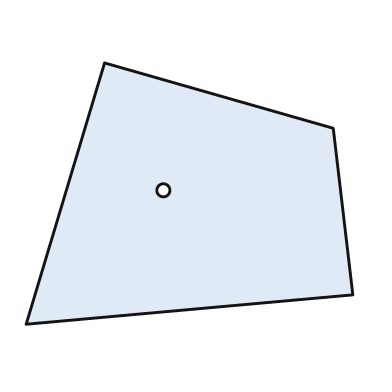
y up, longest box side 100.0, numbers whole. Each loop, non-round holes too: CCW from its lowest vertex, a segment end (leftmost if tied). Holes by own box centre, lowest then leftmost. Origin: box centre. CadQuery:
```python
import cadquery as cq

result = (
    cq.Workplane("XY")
    .moveTo(-50.0, -40.0)
    .lineTo(50.0, -31.0)
    .lineTo(44.0, 20.0)
    .lineTo(-26.0, 40.0)
    .close()
    .moveTo(-8.0, 1.0)
    .circle(2.0)
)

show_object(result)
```